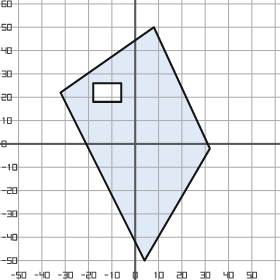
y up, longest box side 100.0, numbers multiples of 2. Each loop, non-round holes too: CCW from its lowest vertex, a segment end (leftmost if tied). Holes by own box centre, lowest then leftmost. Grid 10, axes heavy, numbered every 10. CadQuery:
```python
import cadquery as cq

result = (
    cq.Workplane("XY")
    .moveTo(4.0, -50.0)
    .lineTo(32.0, -2.0)
    .lineTo(8.0, 50.0)
    .lineTo(-32.0, 22.0)
    .close()
    .moveTo(-18.0, 18.0)
    .lineTo(-6.0, 18.0)
    .lineTo(-6.0, 26.0)
    .lineTo(-18.0, 26.0)
    .close()
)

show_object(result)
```